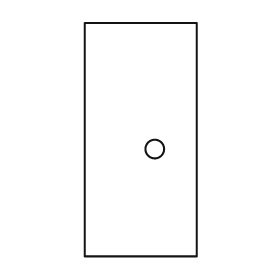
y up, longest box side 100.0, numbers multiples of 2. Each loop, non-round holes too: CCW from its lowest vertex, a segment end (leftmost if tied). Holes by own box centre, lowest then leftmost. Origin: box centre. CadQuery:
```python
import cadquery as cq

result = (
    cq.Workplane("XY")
    .moveTo(-24.0, -50.0)
    .lineTo(24.0, -50.0)
    .lineTo(24.0, 50.0)
    .lineTo(-24.0, 50.0)
    .close()
    .moveTo(6.0, -4.0)
    .circle(4.0)
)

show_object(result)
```